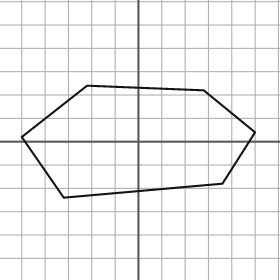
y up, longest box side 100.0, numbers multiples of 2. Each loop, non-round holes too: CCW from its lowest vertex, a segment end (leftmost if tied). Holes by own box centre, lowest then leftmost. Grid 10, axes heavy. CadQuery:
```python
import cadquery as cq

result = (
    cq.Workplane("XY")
    .moveTo(-32.0, -24.0)
    .lineTo(36.0, -18.0)
    .lineTo(50.0, 4.0)
    .lineTo(28.0, 22.0)
    .lineTo(-22.0, 24.0)
    .lineTo(-50.0, 2.0)
    .close()
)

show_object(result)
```